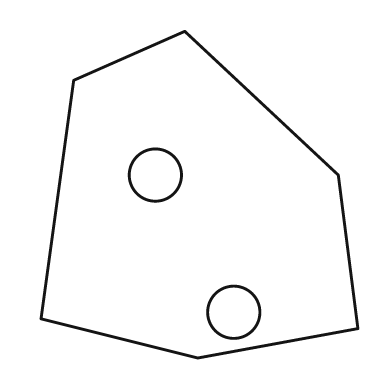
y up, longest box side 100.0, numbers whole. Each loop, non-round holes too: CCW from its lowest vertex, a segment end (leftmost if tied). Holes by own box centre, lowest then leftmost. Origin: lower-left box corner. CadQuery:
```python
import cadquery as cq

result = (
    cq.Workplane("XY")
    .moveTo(48.0, 0.0)
    .lineTo(97.0, 9.0)
    .lineTo(91.0, 56.0)
    .lineTo(44.0, 100.0)
    .lineTo(10.0, 85.0)
    .lineTo(0.0, 12.0)
    .close()
    .moveTo(59.0, 14.0)
    .circle(8.0)
    .moveTo(35.0, 56.0)
    .circle(8.0)
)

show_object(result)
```